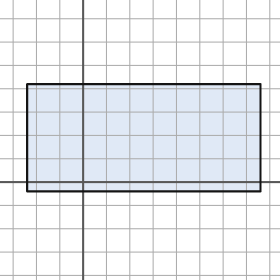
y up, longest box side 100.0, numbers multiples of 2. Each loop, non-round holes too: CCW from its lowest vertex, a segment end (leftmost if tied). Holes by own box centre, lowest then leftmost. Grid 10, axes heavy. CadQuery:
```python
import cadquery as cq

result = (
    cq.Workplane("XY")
    .moveTo(-24.0, -4.0)
    .lineTo(76.0, -4.0)
    .lineTo(76.0, 42.0)
    .lineTo(-24.0, 42.0)
    .close()
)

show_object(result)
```